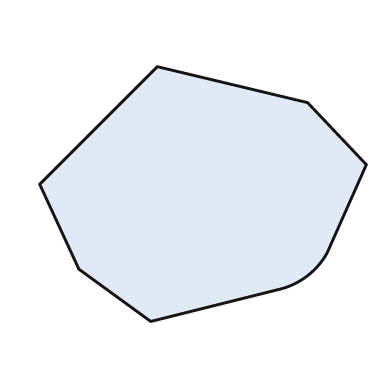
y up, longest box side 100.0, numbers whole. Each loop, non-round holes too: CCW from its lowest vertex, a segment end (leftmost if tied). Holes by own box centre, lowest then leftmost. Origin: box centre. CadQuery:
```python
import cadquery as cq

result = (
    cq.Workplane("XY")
    .moveTo(-16.0, -39.0)
    .lineTo(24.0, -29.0)
    .threePointArc((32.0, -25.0), (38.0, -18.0))
    .lineTo(50.0, 9.0)
    .lineTo(32.0, 28.0)
    .lineTo(-14.0, 39.0)
    .lineTo(-50.0, 3.0)
    .lineTo(-38.0, -23.0)
    .close()
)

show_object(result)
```